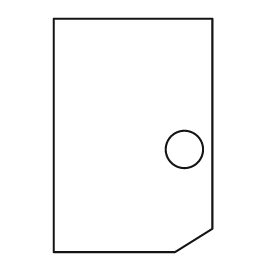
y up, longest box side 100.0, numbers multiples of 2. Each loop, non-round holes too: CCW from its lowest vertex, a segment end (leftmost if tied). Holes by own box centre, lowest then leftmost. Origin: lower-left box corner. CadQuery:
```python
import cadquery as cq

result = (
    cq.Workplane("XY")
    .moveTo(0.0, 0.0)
    .lineTo(52.0, 0.0)
    .lineTo(68.0, 10.0)
    .lineTo(68.0, 100.0)
    .lineTo(0.0, 100.0)
    .close()
    .moveTo(56.0, 44.0)
    .circle(8.0)
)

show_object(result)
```